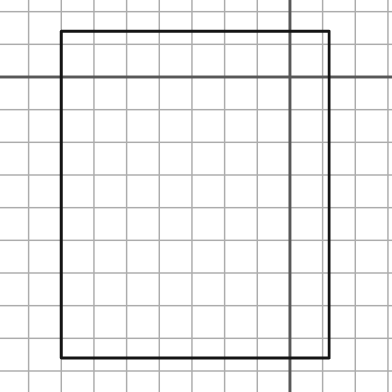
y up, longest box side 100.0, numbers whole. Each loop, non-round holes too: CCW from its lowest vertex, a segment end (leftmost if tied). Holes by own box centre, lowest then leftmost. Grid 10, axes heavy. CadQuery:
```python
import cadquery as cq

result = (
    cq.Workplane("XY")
    .moveTo(-70.0, -86.0)
    .lineTo(12.0, -86.0)
    .lineTo(12.0, 14.0)
    .lineTo(-70.0, 14.0)
    .close()
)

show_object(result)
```